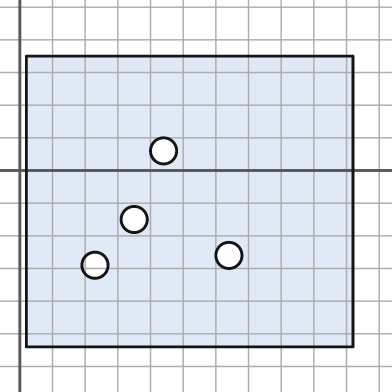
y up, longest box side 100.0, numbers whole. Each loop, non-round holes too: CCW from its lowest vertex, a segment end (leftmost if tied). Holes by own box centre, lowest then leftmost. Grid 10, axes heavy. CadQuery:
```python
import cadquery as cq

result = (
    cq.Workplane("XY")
    .moveTo(2.0, -54.0)
    .lineTo(102.0, -54.0)
    .lineTo(102.0, 35.0)
    .lineTo(2.0, 35.0)
    .close()
    .moveTo(23.0, -29.0)
    .circle(4.0)
    .moveTo(64.0, -26.0)
    .circle(4.0)
    .moveTo(35.0, -15.0)
    .circle(4.0)
    .moveTo(44.0, 6.0)
    .circle(4.0)
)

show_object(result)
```